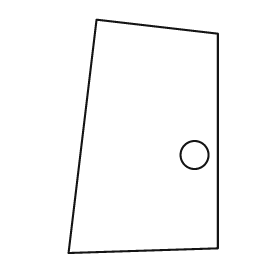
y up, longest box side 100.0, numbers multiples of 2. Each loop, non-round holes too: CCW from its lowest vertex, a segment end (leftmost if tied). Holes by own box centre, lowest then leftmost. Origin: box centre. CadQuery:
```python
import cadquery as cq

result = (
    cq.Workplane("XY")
    .moveTo(-32.0, -50.0)
    .lineTo(32.0, -48.0)
    .lineTo(32.0, 44.0)
    .lineTo(-20.0, 50.0)
    .close()
    .moveTo(22.0, -8.0)
    .circle(6.0)
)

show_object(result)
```